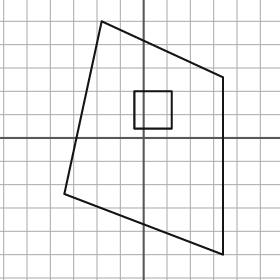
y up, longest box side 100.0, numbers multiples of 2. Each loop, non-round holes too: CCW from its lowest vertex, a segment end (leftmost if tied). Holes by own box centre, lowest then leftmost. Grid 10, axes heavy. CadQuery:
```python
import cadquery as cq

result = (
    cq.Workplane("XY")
    .moveTo(34.0, -50.0)
    .lineTo(34.0, 26.0)
    .lineTo(-18.0, 50.0)
    .lineTo(-34.0, -24.0)
    .close()
    .moveTo(-4.0, 4.0)
    .lineTo(12.0, 4.0)
    .lineTo(12.0, 20.0)
    .lineTo(-4.0, 20.0)
    .close()
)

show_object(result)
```